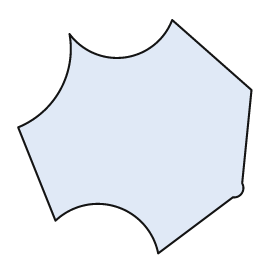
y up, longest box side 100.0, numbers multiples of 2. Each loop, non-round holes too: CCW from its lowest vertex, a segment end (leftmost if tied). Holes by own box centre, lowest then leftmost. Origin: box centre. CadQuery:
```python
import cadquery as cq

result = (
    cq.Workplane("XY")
    .moveTo(10.0, -50.0)
    .lineTo(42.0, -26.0)
    .threePointArc((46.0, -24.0), (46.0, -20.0))
    .lineTo(50.0, 20.0)
    .lineTo(16.0, 50.0)
    .threePointArc((-4.0, 34.0), (-28.0, 44.0))
    .threePointArc((-32.0, 20.0), (-50.0, 4.0))
    .lineTo(-34.0, -36.0)
    .threePointArc((-8.0, -30.0), (10.0, -50.0))
    .close()
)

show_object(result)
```